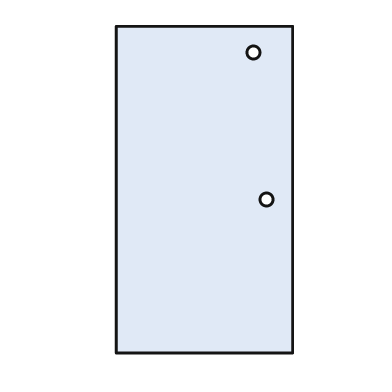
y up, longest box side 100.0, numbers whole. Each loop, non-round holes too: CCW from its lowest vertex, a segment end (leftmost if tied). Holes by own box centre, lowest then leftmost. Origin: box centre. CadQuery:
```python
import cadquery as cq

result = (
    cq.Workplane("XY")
    .moveTo(-27.0, -50.0)
    .lineTo(27.0, -50.0)
    .lineTo(27.0, 50.0)
    .lineTo(-27.0, 50.0)
    .close()
    .moveTo(19.0, -3.0)
    .circle(2.0)
    .moveTo(15.0, 42.0)
    .circle(2.0)
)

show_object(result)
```